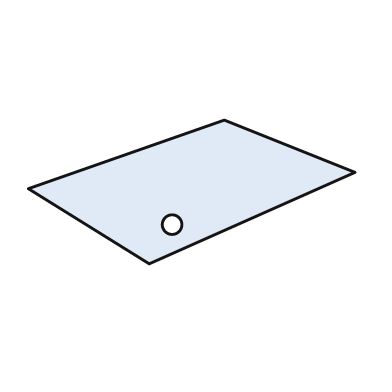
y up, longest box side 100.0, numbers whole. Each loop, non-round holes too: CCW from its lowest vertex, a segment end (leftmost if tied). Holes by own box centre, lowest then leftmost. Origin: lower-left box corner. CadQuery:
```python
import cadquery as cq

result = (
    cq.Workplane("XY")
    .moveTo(37.0, 0.0)
    .lineTo(100.0, 28.0)
    .lineTo(60.0, 44.0)
    .lineTo(0.0, 23.0)
    .close()
    .moveTo(44.0, 12.0)
    .circle(3.0)
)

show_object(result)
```